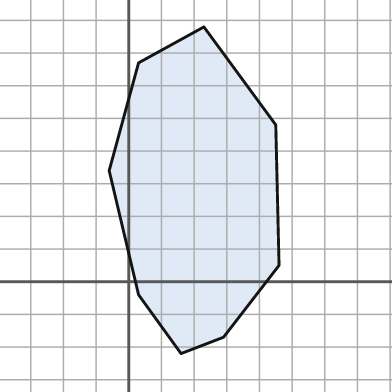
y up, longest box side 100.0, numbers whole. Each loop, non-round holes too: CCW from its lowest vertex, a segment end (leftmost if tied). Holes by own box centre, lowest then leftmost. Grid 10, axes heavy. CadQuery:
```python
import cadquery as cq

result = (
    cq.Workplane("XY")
    .moveTo(16.0, -22.0)
    .lineTo(29.0, -17.0)
    .lineTo(46.0, 5.0)
    .lineTo(45.0, 48.0)
    .lineTo(23.0, 78.0)
    .lineTo(3.0, 67.0)
    .lineTo(-6.0, 34.0)
    .lineTo(3.0, -4.0)
    .close()
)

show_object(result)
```